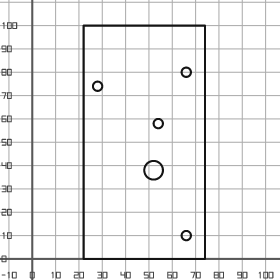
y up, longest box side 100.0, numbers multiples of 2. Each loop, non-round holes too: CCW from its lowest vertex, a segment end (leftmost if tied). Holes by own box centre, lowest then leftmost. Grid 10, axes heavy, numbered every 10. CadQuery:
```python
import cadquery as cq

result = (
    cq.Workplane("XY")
    .moveTo(22.0, 0.0)
    .lineTo(74.0, 0.0)
    .lineTo(74.0, 100.0)
    .lineTo(22.0, 100.0)
    .close()
    .moveTo(66.0, 10.0)
    .circle(2.0)
    .moveTo(52.0, 38.0)
    .circle(4.0)
    .moveTo(54.0, 58.0)
    .circle(2.0)
    .moveTo(28.0, 74.0)
    .circle(2.0)
    .moveTo(66.0, 80.0)
    .circle(2.0)
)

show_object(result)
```